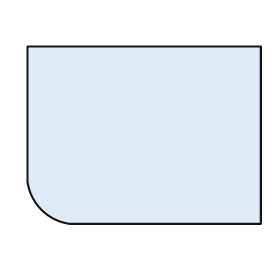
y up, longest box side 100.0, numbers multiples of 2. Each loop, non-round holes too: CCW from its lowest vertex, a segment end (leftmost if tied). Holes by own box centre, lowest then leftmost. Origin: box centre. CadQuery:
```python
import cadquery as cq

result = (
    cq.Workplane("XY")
    .moveTo(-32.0, -38.0)
    .lineTo(50.0, -38.0)
    .lineTo(50.0, 38.0)
    .lineTo(-50.0, 38.0)
    .lineTo(-50.0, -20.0)
    .threePointArc((-44.0, -32.0), (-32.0, -38.0))
    .close()
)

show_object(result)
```